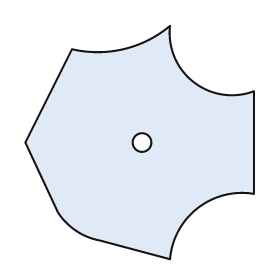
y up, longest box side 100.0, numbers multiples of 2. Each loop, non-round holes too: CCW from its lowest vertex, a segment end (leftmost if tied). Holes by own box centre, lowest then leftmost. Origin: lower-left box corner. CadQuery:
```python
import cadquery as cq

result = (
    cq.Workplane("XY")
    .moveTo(62.0, 0.0)
    .threePointArc((74.0, 22.0), (98.0, 28.0))
    .lineTo(98.0, 72.0)
    .threePointArc((72.0, 76.0), (62.0, 100.0))
    .threePointArc((42.0, 90.0), (20.0, 90.0))
    .lineTo(0.0, 50.0)
    .lineTo(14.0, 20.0)
    .threePointArc((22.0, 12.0), (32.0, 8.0))
    .close()
    .moveTo(50.0, 50.0)
    .circle(4.0)
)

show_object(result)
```